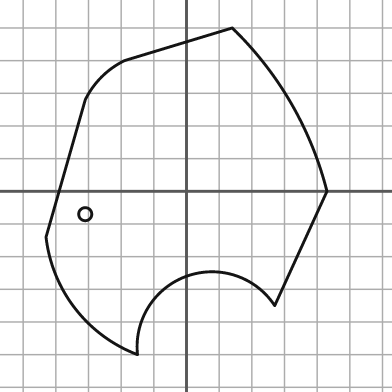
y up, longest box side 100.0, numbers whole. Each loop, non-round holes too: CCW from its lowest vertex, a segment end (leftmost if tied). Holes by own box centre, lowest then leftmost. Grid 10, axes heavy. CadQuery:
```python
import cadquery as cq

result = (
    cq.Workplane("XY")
    .moveTo(-15.0, -50.0)
    .threePointArc((0.0, -26.0), (27.0, -35.0))
    .lineTo(43.0, 0.0)
    .threePointArc((32.0, 27.0), (14.0, 50.0))
    .lineTo(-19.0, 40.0)
    .threePointArc((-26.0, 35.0), (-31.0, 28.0))
    .lineTo(-43.0, -14.0)
    .threePointArc((-34.0, -36.0), (-15.0, -50.0))
    .close()
    .moveTo(-31.0, -7.0)
    .circle(2.0)
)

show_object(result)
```